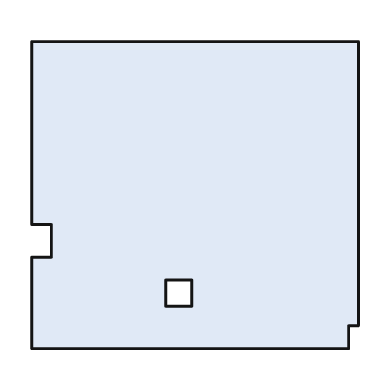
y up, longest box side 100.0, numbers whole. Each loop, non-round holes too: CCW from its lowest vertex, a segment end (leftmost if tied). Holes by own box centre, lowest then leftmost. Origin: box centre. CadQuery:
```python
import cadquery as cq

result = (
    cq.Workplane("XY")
    .moveTo(-50.0, -47.0)
    .lineTo(47.0, -47.0)
    .lineTo(47.0, -40.0)
    .lineTo(50.0, -40.0)
    .lineTo(50.0, 47.0)
    .lineTo(-50.0, 47.0)
    .lineTo(-50.0, -9.0)
    .lineTo(-44.0, -9.0)
    .lineTo(-44.0, -19.0)
    .lineTo(-50.0, -19.0)
    .close()
    .moveTo(-9.0, -34.0)
    .lineTo(-1.0, -34.0)
    .lineTo(-1.0, -26.0)
    .lineTo(-9.0, -26.0)
    .close()
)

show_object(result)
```